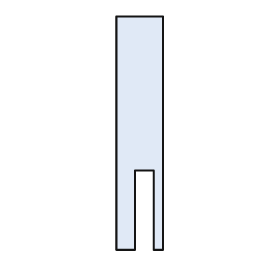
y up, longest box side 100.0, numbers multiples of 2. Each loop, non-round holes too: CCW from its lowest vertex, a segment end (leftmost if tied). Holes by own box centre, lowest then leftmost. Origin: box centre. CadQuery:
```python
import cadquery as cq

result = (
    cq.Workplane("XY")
    .moveTo(-10.0, -50.0)
    .lineTo(-2.0, -50.0)
    .lineTo(-2.0, -16.0)
    .lineTo(6.0, -16.0)
    .lineTo(6.0, -50.0)
    .lineTo(10.0, -50.0)
    .lineTo(10.0, 50.0)
    .lineTo(-10.0, 50.0)
    .close()
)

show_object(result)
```